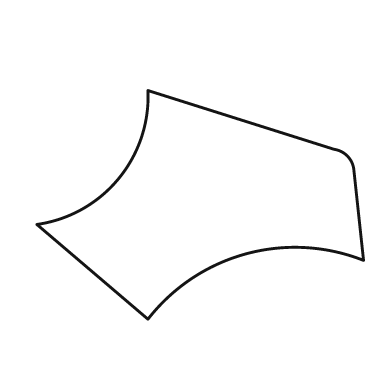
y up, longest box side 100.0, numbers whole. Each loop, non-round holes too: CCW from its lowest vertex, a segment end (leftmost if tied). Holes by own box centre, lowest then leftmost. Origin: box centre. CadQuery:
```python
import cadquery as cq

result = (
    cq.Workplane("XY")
    .moveTo(-16.0, -35.0)
    .threePointArc((14.0, -15.0), (50.0, -17.0))
    .lineTo(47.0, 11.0)
    .threePointArc((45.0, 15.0), (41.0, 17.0))
    .lineTo(-16.0, 35.0)
    .threePointArc((-25.0, 8.0), (-50.0, -6.0))
    .close()
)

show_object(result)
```